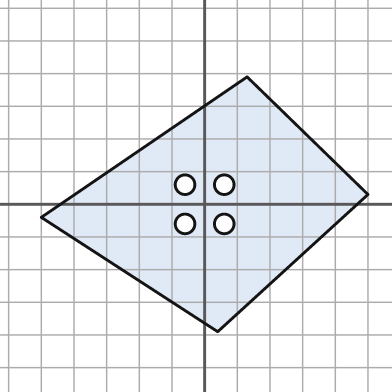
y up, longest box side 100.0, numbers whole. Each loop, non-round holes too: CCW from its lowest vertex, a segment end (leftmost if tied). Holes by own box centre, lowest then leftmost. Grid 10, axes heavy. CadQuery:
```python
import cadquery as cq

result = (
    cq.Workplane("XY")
    .moveTo(4.0, -39.0)
    .lineTo(50.0, 3.0)
    .lineTo(13.0, 39.0)
    .lineTo(-50.0, -4.0)
    .close()
    .moveTo(-6.0, -6.0)
    .circle(3.0)
    .moveTo(6.0, -6.0)
    .circle(3.0)
    .moveTo(-6.0, 6.0)
    .circle(3.0)
    .moveTo(6.0, 6.0)
    .circle(3.0)
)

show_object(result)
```